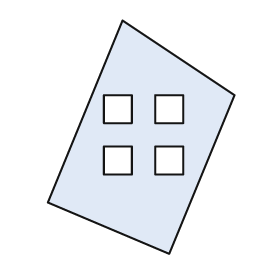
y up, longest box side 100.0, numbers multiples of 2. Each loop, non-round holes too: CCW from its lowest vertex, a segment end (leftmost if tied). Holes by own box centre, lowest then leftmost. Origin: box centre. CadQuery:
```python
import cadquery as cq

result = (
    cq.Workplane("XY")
    .moveTo(12.0, -50.0)
    .lineTo(40.0, 18.0)
    .lineTo(-8.0, 50.0)
    .lineTo(-40.0, -28.0)
    .close()
    .moveTo(-16.0, -16.0)
    .lineTo(-4.0, -16.0)
    .lineTo(-4.0, -4.0)
    .lineTo(-16.0, -4.0)
    .close()
    .moveTo(6.0, -16.0)
    .lineTo(18.0, -16.0)
    .lineTo(18.0, -4.0)
    .lineTo(6.0, -4.0)
    .close()
    .moveTo(-16.0, 6.0)
    .lineTo(-4.0, 6.0)
    .lineTo(-4.0, 18.0)
    .lineTo(-16.0, 18.0)
    .close()
    .moveTo(6.0, 6.0)
    .lineTo(18.0, 6.0)
    .lineTo(18.0, 18.0)
    .lineTo(6.0, 18.0)
    .close()
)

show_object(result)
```